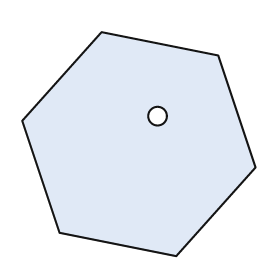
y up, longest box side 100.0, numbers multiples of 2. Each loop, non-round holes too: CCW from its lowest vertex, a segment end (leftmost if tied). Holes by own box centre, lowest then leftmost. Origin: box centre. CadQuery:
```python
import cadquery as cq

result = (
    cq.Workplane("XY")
    .moveTo(16.0, -48.0)
    .lineTo(50.0, -10.0)
    .lineTo(34.0, 38.0)
    .lineTo(-16.0, 48.0)
    .lineTo(-50.0, 10.0)
    .lineTo(-34.0, -38.0)
    .close()
    .moveTo(8.0, 12.0)
    .circle(4.0)
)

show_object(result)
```